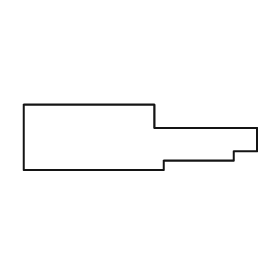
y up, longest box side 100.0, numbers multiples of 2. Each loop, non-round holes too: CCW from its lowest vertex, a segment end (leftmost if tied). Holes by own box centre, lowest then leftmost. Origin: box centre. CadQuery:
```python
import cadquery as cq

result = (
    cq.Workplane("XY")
    .moveTo(-50.0, -14.0)
    .lineTo(10.0, -14.0)
    .lineTo(10.0, -10.0)
    .lineTo(40.0, -10.0)
    .lineTo(40.0, -6.0)
    .lineTo(50.0, -6.0)
    .lineTo(50.0, 4.0)
    .lineTo(6.0, 4.0)
    .lineTo(6.0, 14.0)
    .lineTo(-50.0, 14.0)
    .close()
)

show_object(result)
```